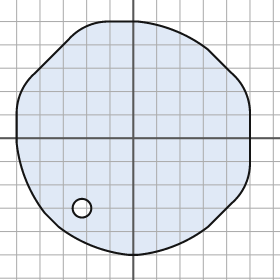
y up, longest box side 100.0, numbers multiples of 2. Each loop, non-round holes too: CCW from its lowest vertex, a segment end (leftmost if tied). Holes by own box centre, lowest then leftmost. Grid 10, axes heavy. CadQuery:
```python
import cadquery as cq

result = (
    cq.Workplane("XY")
    .moveTo(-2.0, -50.0)
    .lineTo(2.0, -50.0)
    .threePointArc((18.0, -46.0), (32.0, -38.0))
    .lineTo(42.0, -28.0)
    .threePointArc((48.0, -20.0), (50.0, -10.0))
    .lineTo(50.0, 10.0)
    .threePointArc((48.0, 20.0), (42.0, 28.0))
    .lineTo(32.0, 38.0)
    .threePointArc((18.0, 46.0), (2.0, 50.0))
    .lineTo(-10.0, 50.0)
    .threePointArc((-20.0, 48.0), (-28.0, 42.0))
    .lineTo(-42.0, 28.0)
    .threePointArc((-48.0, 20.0), (-50.0, 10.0))
    .lineTo(-50.0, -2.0)
    .threePointArc((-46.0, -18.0), (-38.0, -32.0))
    .lineTo(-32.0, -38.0)
    .threePointArc((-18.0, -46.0), (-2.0, -50.0))
    .close()
    .moveTo(-22.0, -30.0)
    .circle(4.0)
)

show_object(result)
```